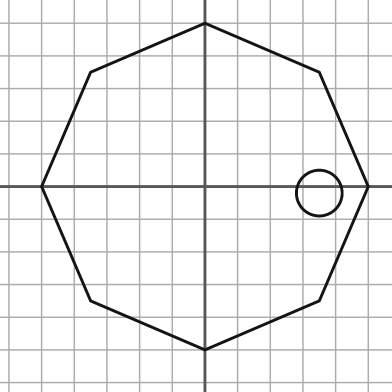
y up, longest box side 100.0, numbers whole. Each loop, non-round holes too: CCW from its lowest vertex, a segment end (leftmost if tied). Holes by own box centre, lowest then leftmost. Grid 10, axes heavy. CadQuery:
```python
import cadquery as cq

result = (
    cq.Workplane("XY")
    .moveTo(0.0, -50.0)
    .lineTo(35.0, -35.0)
    .lineTo(50.0, 0.0)
    .lineTo(35.0, 35.0)
    .lineTo(0.0, 50.0)
    .lineTo(-35.0, 35.0)
    .lineTo(-50.0, 0.0)
    .lineTo(-35.0, -35.0)
    .close()
    .moveTo(35.0, -2.0)
    .circle(7.0)
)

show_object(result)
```